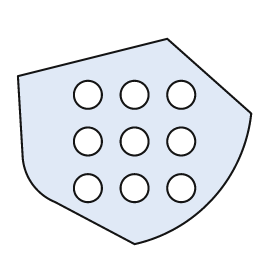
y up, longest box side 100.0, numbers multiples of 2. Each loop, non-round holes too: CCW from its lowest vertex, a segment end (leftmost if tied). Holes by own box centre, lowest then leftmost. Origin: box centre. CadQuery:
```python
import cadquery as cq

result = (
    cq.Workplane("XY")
    .moveTo(0.0, -44.0)
    .threePointArc((34.0, -24.0), (50.0, 12.0))
    .lineTo(14.0, 44.0)
    .lineTo(-50.0, 28.0)
    .lineTo(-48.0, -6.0)
    .threePointArc((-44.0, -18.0), (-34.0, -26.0))
    .close()
    .moveTo(-20.0, -20.0)
    .circle(6.0)
    .moveTo(0.0, -20.0)
    .circle(6.0)
    .moveTo(20.0, -20.0)
    .circle(6.0)
    .moveTo(-20.0, 0.0)
    .circle(6.0)
    .moveTo(0.0, 0.0)
    .circle(6.0)
    .moveTo(20.0, 0.0)
    .circle(6.0)
    .moveTo(-20.0, 20.0)
    .circle(6.0)
    .moveTo(0.0, 20.0)
    .circle(6.0)
    .moveTo(20.0, 20.0)
    .circle(6.0)
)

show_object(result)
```